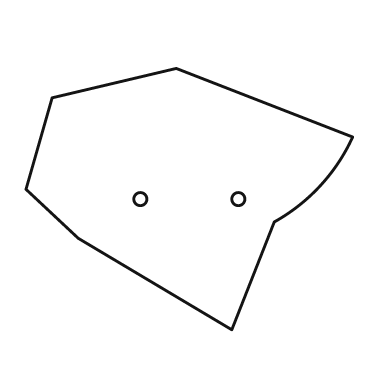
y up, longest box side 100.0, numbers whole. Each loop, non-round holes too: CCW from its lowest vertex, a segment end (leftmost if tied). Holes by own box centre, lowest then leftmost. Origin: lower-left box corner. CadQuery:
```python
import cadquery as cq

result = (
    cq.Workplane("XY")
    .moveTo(63.0, 0.0)
    .lineTo(76.0, 33.0)
    .threePointArc((90.0, 44.0), (100.0, 59.0))
    .lineTo(46.0, 80.0)
    .lineTo(8.0, 71.0)
    .lineTo(0.0, 43.0)
    .lineTo(16.0, 28.0)
    .close()
    .moveTo(35.0, 40.0)
    .circle(2.0)
    .moveTo(65.0, 40.0)
    .circle(2.0)
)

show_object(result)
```